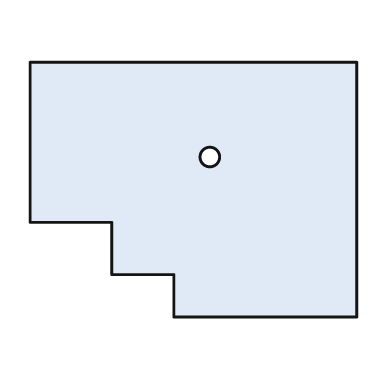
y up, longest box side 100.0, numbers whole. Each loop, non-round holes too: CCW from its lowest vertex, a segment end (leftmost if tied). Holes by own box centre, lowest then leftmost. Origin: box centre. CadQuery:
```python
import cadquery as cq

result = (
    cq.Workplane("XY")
    .moveTo(-6.0, -39.0)
    .lineTo(50.0, -39.0)
    .lineTo(50.0, 39.0)
    .lineTo(-50.0, 39.0)
    .lineTo(-50.0, -10.0)
    .lineTo(-25.0, -10.0)
    .lineTo(-25.0, -26.0)
    .lineTo(-6.0, -26.0)
    .close()
    .moveTo(5.0, 10.0)
    .circle(3.0)
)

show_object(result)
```